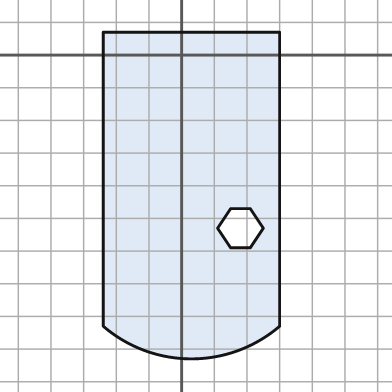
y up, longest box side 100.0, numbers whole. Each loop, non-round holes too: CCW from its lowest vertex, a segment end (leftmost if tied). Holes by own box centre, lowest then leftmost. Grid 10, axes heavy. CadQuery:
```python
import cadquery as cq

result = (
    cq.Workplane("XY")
    .moveTo(-24.0, -83.0)
    .threePointArc((3.0, -93.0), (30.0, -83.0))
    .lineTo(30.0, 7.0)
    .lineTo(-24.0, 7.0)
    .close()
    .moveTo(15.0, -59.0)
    .lineTo(21.0, -59.0)
    .lineTo(25.0, -53.0)
    .lineTo(21.0, -47.0)
    .lineTo(15.0, -47.0)
    .lineTo(11.0, -53.0)
    .close()
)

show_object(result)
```